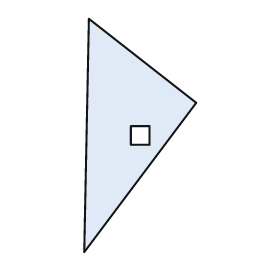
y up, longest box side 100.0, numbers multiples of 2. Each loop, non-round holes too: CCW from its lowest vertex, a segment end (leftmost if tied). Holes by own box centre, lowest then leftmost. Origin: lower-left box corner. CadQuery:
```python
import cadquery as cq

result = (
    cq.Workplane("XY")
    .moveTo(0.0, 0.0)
    .lineTo(48.0, 64.0)
    .lineTo(2.0, 100.0)
    .close()
    .moveTo(20.0, 46.0)
    .lineTo(28.0, 46.0)
    .lineTo(28.0, 54.0)
    .lineTo(20.0, 54.0)
    .close()
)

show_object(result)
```